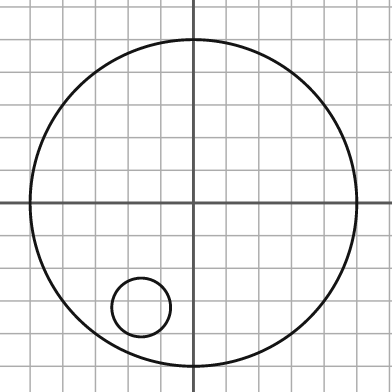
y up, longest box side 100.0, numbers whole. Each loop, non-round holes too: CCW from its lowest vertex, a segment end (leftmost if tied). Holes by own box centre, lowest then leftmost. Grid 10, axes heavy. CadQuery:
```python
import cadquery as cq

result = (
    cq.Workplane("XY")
    .moveTo(0.0, 0.0)
    .circle(50.0)
    .moveTo(-16.0, -32.0)
    .circle(9.0)
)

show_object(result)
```